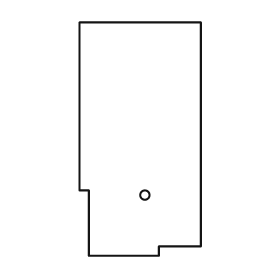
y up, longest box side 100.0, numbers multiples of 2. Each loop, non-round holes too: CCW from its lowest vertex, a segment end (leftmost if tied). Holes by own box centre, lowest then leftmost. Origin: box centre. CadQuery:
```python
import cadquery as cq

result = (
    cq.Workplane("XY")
    .moveTo(-22.0, -50.0)
    .lineTo(8.0, -50.0)
    .lineTo(8.0, -46.0)
    .lineTo(26.0, -46.0)
    .lineTo(26.0, 50.0)
    .lineTo(-26.0, 50.0)
    .lineTo(-26.0, -22.0)
    .lineTo(-22.0, -22.0)
    .close()
    .moveTo(2.0, -24.0)
    .circle(2.0)
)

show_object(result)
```